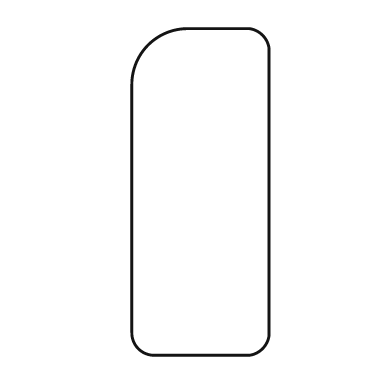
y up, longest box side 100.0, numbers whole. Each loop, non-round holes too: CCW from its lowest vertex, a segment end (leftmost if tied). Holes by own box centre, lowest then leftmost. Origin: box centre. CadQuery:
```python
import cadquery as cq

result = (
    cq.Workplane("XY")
    .moveTo(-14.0, -50.0)
    .lineTo(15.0, -50.0)
    .threePointArc((19.0, -48.0), (21.0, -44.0))
    .lineTo(21.0, 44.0)
    .threePointArc((19.0, 48.0), (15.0, 50.0))
    .lineTo(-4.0, 50.0)
    .threePointArc((-16.0, 45.0), (-21.0, 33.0))
    .lineTo(-21.0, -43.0)
    .threePointArc((-19.0, -48.0), (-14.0, -50.0))
    .close()
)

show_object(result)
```